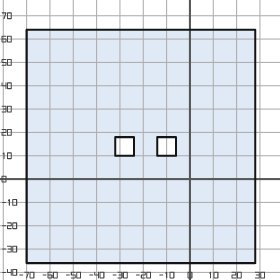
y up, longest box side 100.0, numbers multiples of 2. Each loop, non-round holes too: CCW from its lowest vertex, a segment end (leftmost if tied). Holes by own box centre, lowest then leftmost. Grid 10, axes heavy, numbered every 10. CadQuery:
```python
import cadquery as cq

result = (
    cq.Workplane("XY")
    .moveTo(-70.0, -36.0)
    .lineTo(28.0, -36.0)
    .lineTo(28.0, 64.0)
    .lineTo(-70.0, 64.0)
    .close()
    .moveTo(-32.0, 10.0)
    .lineTo(-24.0, 10.0)
    .lineTo(-24.0, 18.0)
    .lineTo(-32.0, 18.0)
    .close()
    .moveTo(-14.0, 10.0)
    .lineTo(-6.0, 10.0)
    .lineTo(-6.0, 18.0)
    .lineTo(-14.0, 18.0)
    .close()
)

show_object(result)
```